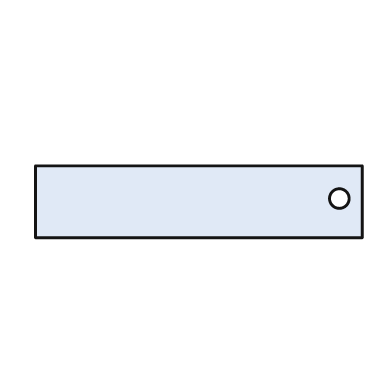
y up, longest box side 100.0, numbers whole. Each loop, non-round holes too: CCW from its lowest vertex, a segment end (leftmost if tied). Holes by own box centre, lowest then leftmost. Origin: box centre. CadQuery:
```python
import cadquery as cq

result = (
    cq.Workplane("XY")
    .moveTo(-50.0, -11.0)
    .lineTo(50.0, -11.0)
    .lineTo(50.0, 11.0)
    .lineTo(-50.0, 11.0)
    .close()
    .moveTo(43.0, 1.0)
    .circle(3.0)
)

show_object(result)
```